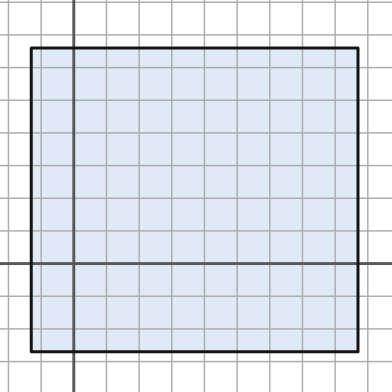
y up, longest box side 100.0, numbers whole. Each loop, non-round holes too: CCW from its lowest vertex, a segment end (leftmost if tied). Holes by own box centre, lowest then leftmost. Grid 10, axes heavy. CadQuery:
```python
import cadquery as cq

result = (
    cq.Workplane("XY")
    .moveTo(-13.0, -27.0)
    .lineTo(87.0, -27.0)
    .lineTo(87.0, 66.0)
    .lineTo(-13.0, 66.0)
    .close()
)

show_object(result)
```